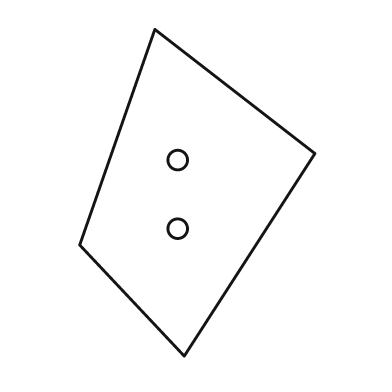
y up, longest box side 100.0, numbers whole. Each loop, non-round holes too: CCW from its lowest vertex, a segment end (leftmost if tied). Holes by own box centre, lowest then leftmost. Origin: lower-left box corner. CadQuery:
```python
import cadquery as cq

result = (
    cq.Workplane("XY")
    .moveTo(32.0, 0.0)
    .lineTo(72.0, 62.0)
    .lineTo(23.0, 100.0)
    .lineTo(0.0, 34.0)
    .close()
    .moveTo(30.0, 39.0)
    .circle(3.0)
    .moveTo(30.0, 60.0)
    .circle(3.0)
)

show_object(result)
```